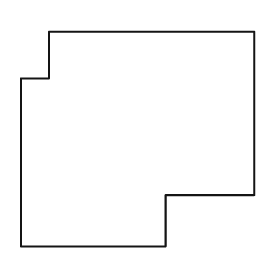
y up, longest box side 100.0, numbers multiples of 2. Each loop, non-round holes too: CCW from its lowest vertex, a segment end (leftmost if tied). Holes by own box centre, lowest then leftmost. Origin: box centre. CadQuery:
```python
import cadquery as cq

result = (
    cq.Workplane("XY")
    .moveTo(-50.0, -46.0)
    .lineTo(12.0, -46.0)
    .lineTo(12.0, -24.0)
    .lineTo(50.0, -24.0)
    .lineTo(50.0, 46.0)
    .lineTo(-38.0, 46.0)
    .lineTo(-38.0, 26.0)
    .lineTo(-50.0, 26.0)
    .close()
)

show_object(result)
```